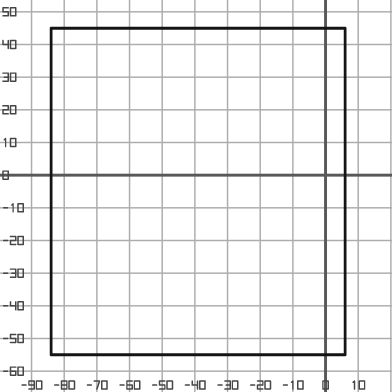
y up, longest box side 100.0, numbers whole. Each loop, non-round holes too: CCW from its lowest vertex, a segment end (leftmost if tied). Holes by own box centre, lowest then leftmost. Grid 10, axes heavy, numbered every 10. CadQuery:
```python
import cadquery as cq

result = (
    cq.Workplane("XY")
    .moveTo(-84.0, -55.0)
    .lineTo(6.0, -55.0)
    .lineTo(6.0, 45.0)
    .lineTo(-84.0, 45.0)
    .close()
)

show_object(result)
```